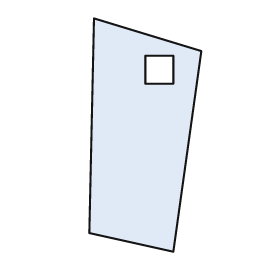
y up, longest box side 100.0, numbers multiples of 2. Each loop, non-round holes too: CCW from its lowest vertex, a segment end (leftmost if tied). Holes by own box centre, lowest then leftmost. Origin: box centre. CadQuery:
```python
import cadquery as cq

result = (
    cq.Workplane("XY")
    .moveTo(12.0, -50.0)
    .lineTo(24.0, 36.0)
    .lineTo(-22.0, 50.0)
    .lineTo(-24.0, -42.0)
    .close()
    .moveTo(0.0, 22.0)
    .lineTo(12.0, 22.0)
    .lineTo(12.0, 34.0)
    .lineTo(0.0, 34.0)
    .close()
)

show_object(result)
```